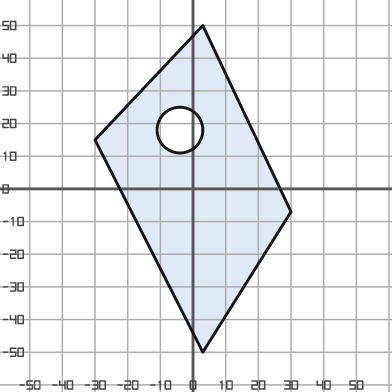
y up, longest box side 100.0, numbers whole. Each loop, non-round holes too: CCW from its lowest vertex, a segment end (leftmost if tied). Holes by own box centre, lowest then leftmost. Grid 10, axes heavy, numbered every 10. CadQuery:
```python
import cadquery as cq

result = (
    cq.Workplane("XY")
    .moveTo(3.0, -50.0)
    .lineTo(30.0, -7.0)
    .lineTo(3.0, 50.0)
    .lineTo(-30.0, 15.0)
    .close()
    .moveTo(-4.0, 18.0)
    .circle(7.0)
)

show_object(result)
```